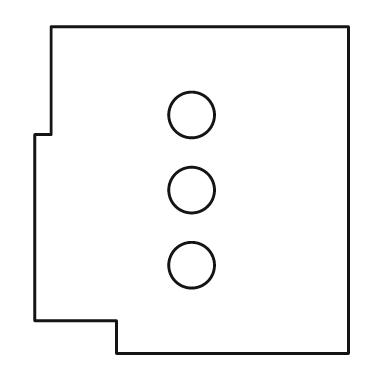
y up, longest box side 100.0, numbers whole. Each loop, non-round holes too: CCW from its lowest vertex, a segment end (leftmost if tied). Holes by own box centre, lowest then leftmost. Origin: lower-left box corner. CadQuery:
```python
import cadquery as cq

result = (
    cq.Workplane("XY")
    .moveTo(25.0, 0.0)
    .lineTo(96.0, 0.0)
    .lineTo(96.0, 100.0)
    .lineTo(5.0, 100.0)
    .lineTo(5.0, 67.0)
    .lineTo(0.0, 67.0)
    .lineTo(0.0, 10.0)
    .lineTo(25.0, 10.0)
    .close()
    .moveTo(48.0, 27.0)
    .circle(7.0)
    .moveTo(48.0, 50.0)
    .circle(7.0)
    .moveTo(48.0, 73.0)
    .circle(7.0)
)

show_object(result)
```